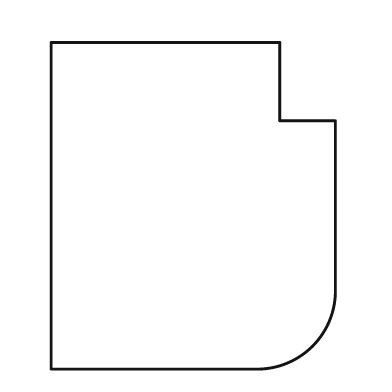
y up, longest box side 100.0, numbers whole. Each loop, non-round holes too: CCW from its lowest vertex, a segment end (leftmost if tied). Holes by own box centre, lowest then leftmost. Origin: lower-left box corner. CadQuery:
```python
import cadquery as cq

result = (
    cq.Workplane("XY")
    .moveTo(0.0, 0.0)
    .lineTo(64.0, 0.0)
    .threePointArc((80.0, 7.0), (87.0, 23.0))
    .lineTo(87.0, 76.0)
    .lineTo(70.0, 76.0)
    .lineTo(70.0, 100.0)
    .lineTo(0.0, 100.0)
    .close()
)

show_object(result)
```